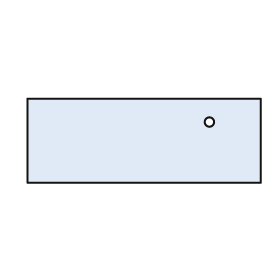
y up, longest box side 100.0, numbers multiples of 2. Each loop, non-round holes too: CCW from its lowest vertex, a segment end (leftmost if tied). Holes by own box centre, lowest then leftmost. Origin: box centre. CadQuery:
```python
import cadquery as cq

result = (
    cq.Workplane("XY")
    .moveTo(-50.0, -18.0)
    .lineTo(50.0, -18.0)
    .lineTo(50.0, 18.0)
    .lineTo(-50.0, 18.0)
    .close()
    .moveTo(28.0, 8.0)
    .circle(2.0)
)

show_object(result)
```